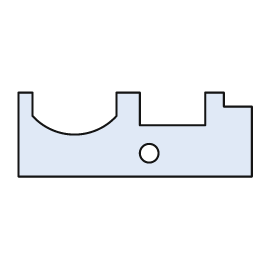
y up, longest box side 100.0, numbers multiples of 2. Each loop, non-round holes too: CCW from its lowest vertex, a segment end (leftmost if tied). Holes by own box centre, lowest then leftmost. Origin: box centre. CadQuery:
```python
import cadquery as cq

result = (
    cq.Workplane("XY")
    .moveTo(-50.0, -18.0)
    .lineTo(50.0, -18.0)
    .lineTo(50.0, 12.0)
    .lineTo(38.0, 12.0)
    .lineTo(38.0, 18.0)
    .lineTo(30.0, 18.0)
    .lineTo(30.0, 4.0)
    .lineTo(2.0, 4.0)
    .lineTo(2.0, 18.0)
    .lineTo(-8.0, 18.0)
    .lineTo(-8.0, 8.0)
    .threePointArc((-26.0, 0.0), (-44.0, 8.0))
    .lineTo(-44.0, 18.0)
    .lineTo(-50.0, 18.0)
    .close()
    .moveTo(6.0, -8.0)
    .circle(4.0)
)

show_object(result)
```